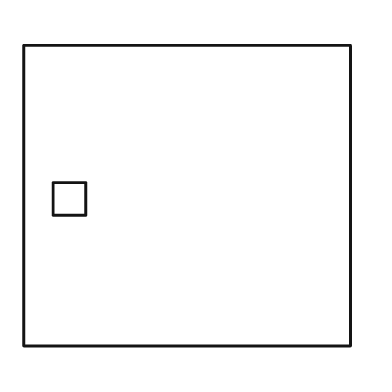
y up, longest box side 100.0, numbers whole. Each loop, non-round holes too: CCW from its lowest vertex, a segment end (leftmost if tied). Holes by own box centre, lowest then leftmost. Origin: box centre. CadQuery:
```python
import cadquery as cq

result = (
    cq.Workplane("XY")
    .moveTo(-50.0, -46.0)
    .lineTo(50.0, -46.0)
    .lineTo(50.0, 46.0)
    .lineTo(-50.0, 46.0)
    .close()
    .moveTo(-41.0, -6.0)
    .lineTo(-31.0, -6.0)
    .lineTo(-31.0, 4.0)
    .lineTo(-41.0, 4.0)
    .close()
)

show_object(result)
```